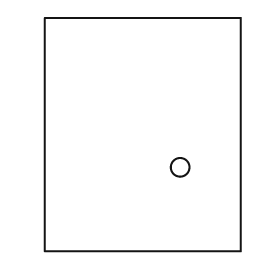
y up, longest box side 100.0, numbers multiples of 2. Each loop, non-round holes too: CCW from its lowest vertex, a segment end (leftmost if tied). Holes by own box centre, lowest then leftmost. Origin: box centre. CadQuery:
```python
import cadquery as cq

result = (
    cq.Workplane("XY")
    .moveTo(-42.0, -50.0)
    .lineTo(42.0, -50.0)
    .lineTo(42.0, 50.0)
    .lineTo(-42.0, 50.0)
    .close()
    .moveTo(16.0, -14.0)
    .circle(4.0)
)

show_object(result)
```